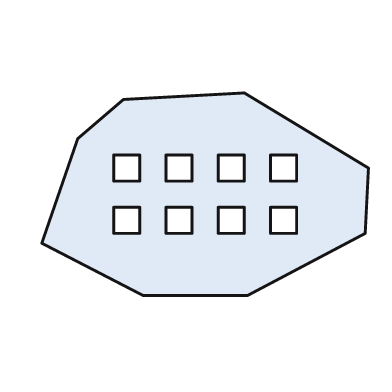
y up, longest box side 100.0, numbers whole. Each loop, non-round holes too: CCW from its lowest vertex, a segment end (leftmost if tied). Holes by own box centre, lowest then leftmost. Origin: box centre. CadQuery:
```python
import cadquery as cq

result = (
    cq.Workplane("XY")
    .moveTo(-19.0, -31.0)
    .lineTo(13.0, -31.0)
    .lineTo(49.0, -12.0)
    .lineTo(50.0, 8.0)
    .lineTo(12.0, 31.0)
    .lineTo(-25.0, 29.0)
    .lineTo(-39.0, 17.0)
    .lineTo(-50.0, -15.0)
    .close()
    .moveTo(-28.0, -12.0)
    .lineTo(-20.0, -12.0)
    .lineTo(-20.0, -4.0)
    .lineTo(-28.0, -4.0)
    .close()
    .moveTo(-12.0, -12.0)
    .lineTo(-4.0, -12.0)
    .lineTo(-4.0, -4.0)
    .lineTo(-12.0, -4.0)
    .close()
    .moveTo(4.0, -12.0)
    .lineTo(12.0, -12.0)
    .lineTo(12.0, -4.0)
    .lineTo(4.0, -4.0)
    .close()
    .moveTo(20.0, -12.0)
    .lineTo(28.0, -12.0)
    .lineTo(28.0, -4.0)
    .lineTo(20.0, -4.0)
    .close()
    .moveTo(-28.0, 4.0)
    .lineTo(-20.0, 4.0)
    .lineTo(-20.0, 12.0)
    .lineTo(-28.0, 12.0)
    .close()
    .moveTo(-12.0, 4.0)
    .lineTo(-4.0, 4.0)
    .lineTo(-4.0, 12.0)
    .lineTo(-12.0, 12.0)
    .close()
    .moveTo(4.0, 4.0)
    .lineTo(12.0, 4.0)
    .lineTo(12.0, 12.0)
    .lineTo(4.0, 12.0)
    .close()
    .moveTo(20.0, 4.0)
    .lineTo(28.0, 4.0)
    .lineTo(28.0, 12.0)
    .lineTo(20.0, 12.0)
    .close()
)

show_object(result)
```